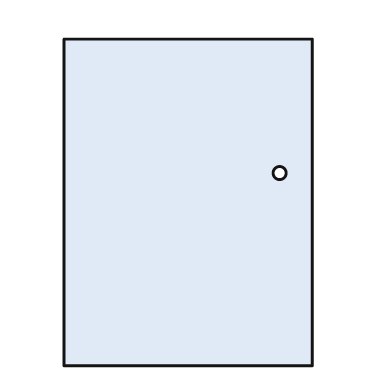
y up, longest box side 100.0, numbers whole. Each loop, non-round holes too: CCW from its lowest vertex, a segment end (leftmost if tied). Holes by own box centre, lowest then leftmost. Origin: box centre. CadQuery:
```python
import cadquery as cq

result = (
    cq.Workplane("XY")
    .moveTo(-38.0, -50.0)
    .lineTo(38.0, -50.0)
    .lineTo(38.0, 50.0)
    .lineTo(-38.0, 50.0)
    .close()
    .moveTo(28.0, 9.0)
    .circle(2.0)
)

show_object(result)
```